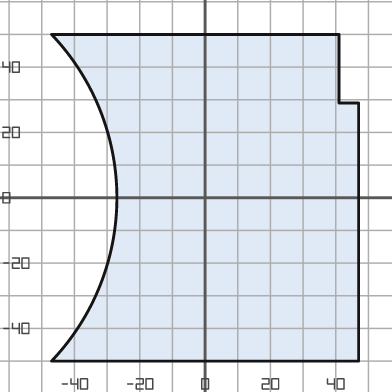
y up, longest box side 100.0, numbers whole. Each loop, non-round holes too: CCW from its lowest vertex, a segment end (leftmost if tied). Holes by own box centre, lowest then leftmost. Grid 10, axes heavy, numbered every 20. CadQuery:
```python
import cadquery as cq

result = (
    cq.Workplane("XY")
    .moveTo(-47.0, -50.0)
    .lineTo(47.0, -50.0)
    .lineTo(47.0, 29.0)
    .lineTo(41.0, 29.0)
    .lineTo(41.0, 50.0)
    .lineTo(-47.0, 50.0)
    .threePointArc((-27.0, 0.0), (-47.0, -50.0))
    .close()
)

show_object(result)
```